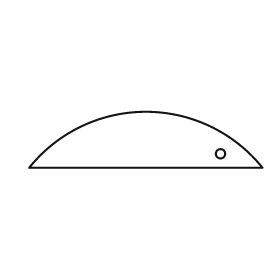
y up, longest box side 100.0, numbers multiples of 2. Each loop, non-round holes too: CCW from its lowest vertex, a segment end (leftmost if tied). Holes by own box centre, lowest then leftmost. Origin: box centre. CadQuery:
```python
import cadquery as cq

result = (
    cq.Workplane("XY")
    .moveTo(-50.0, -12.0)
    .lineTo(50.0, -12.0)
    .threePointArc((0.0, 12.0), (-50.0, -12.0))
    .close()
    .moveTo(32.0, -6.0)
    .circle(2.0)
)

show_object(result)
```